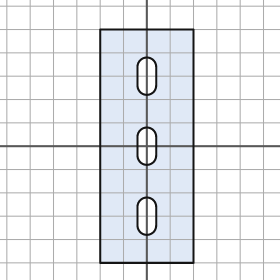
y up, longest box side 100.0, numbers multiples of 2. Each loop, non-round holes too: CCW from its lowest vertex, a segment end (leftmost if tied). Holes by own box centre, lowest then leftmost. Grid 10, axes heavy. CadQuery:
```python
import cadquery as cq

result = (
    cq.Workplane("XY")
    .moveTo(-20.0, -50.0)
    .lineTo(20.0, -50.0)
    .lineTo(20.0, 50.0)
    .lineTo(-20.0, 50.0)
    .close()
    .moveTo(-4.0, -34.0)
    .threePointArc((0.0, -38.0), (4.0, -34.0))
    .lineTo(4.0, -26.0)
    .threePointArc((0.0, -22.0), (-4.0, -26.0))
    .close()
    .moveTo(-4.0, -4.0)
    .threePointArc((0.0, -8.0), (4.0, -4.0))
    .lineTo(4.0, 4.0)
    .threePointArc((0.0, 8.0), (-4.0, 4.0))
    .close()
    .moveTo(-4.0, 26.0)
    .threePointArc((0.0, 22.0), (4.0, 26.0))
    .lineTo(4.0, 34.0)
    .threePointArc((0.0, 38.0), (-4.0, 34.0))
    .close()
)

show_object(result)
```